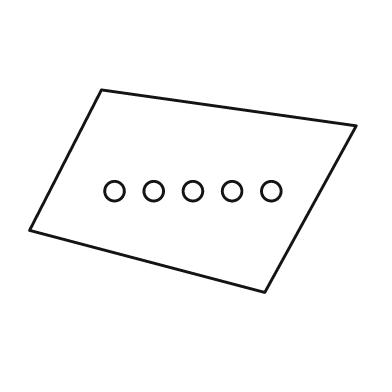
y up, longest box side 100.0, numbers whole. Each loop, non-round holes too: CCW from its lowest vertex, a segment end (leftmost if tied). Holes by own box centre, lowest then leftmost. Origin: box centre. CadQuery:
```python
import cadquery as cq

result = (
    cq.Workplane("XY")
    .moveTo(22.0, -31.0)
    .lineTo(50.0, 20.0)
    .lineTo(-28.0, 31.0)
    .lineTo(-50.0, -12.0)
    .close()
    .moveTo(-24.0, 0.0)
    .circle(3.0)
    .moveTo(-12.0, 0.0)
    .circle(3.0)
    .moveTo(0.0, 0.0)
    .circle(3.0)
    .moveTo(12.0, 0.0)
    .circle(3.0)
    .moveTo(24.0, 0.0)
    .circle(3.0)
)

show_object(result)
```